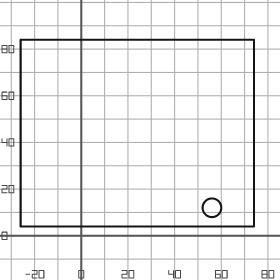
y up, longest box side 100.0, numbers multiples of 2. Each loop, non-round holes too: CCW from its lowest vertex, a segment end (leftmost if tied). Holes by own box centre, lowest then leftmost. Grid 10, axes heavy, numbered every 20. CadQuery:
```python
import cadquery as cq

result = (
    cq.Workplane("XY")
    .moveTo(-26.0, 4.0)
    .lineTo(74.0, 4.0)
    .lineTo(74.0, 84.0)
    .lineTo(-26.0, 84.0)
    .close()
    .moveTo(56.0, 12.0)
    .circle(4.0)
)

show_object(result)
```